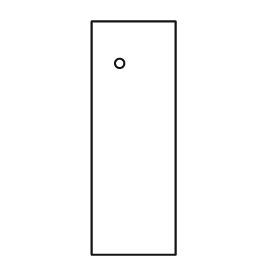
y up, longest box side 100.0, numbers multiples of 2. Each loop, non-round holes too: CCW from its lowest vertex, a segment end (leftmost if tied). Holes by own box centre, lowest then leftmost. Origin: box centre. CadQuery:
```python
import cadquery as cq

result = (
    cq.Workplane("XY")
    .moveTo(-18.0, -50.0)
    .lineTo(18.0, -50.0)
    .lineTo(18.0, 50.0)
    .lineTo(-18.0, 50.0)
    .close()
    .moveTo(-6.0, 32.0)
    .circle(2.0)
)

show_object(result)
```